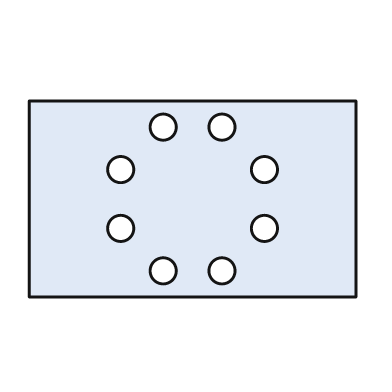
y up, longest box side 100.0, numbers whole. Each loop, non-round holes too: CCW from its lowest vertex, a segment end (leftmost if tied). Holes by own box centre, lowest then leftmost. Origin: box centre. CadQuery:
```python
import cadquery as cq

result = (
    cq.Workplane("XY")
    .moveTo(-50.0, -30.0)
    .lineTo(50.0, -30.0)
    .lineTo(50.0, 30.0)
    .lineTo(-50.0, 30.0)
    .close()
    .moveTo(-9.0, -22.0)
    .circle(4.0)
    .moveTo(9.0, -22.0)
    .circle(4.0)
    .moveTo(-22.0, -9.0)
    .circle(4.0)
    .moveTo(22.0, -9.0)
    .circle(4.0)
    .moveTo(-22.0, 9.0)
    .circle(4.0)
    .moveTo(22.0, 9.0)
    .circle(4.0)
    .moveTo(-9.0, 22.0)
    .circle(4.0)
    .moveTo(9.0, 22.0)
    .circle(4.0)
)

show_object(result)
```